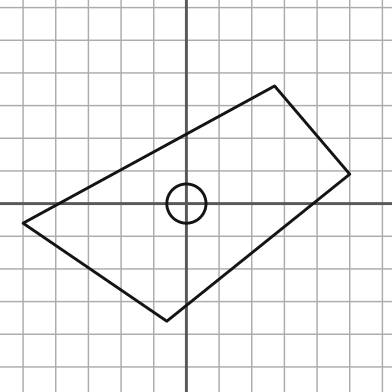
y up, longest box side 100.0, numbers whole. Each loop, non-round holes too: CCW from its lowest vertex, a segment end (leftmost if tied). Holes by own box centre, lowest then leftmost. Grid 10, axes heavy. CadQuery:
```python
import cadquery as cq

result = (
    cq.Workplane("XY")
    .moveTo(-6.0, -36.0)
    .lineTo(50.0, 9.0)
    .lineTo(27.0, 36.0)
    .lineTo(-50.0, -6.0)
    .close()
    .moveTo(0.0, 0.0)
    .circle(6.0)
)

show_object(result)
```